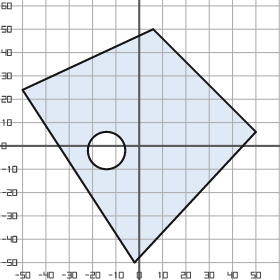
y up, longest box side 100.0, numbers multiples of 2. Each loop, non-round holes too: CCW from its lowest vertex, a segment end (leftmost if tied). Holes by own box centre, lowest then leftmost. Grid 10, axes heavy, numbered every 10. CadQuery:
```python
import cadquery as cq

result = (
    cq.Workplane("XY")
    .moveTo(-2.0, -50.0)
    .lineTo(50.0, 6.0)
    .lineTo(6.0, 50.0)
    .lineTo(-50.0, 24.0)
    .close()
    .moveTo(-14.0, -2.0)
    .circle(8.0)
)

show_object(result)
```